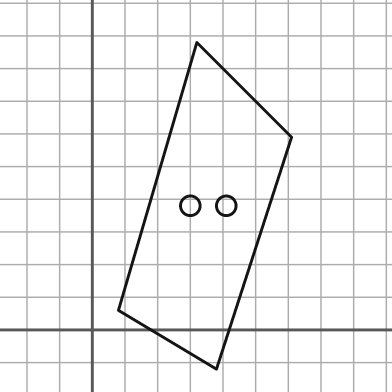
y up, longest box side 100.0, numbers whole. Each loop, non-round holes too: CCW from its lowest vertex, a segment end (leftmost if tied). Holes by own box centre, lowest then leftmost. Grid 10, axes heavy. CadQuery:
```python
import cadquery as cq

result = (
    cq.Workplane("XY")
    .moveTo(38.0, -12.0)
    .lineTo(61.0, 59.0)
    .lineTo(32.0, 88.0)
    .lineTo(8.0, 6.0)
    .close()
    .moveTo(30.0, 38.0)
    .circle(3.0)
    .moveTo(41.0, 38.0)
    .circle(3.0)
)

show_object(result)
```